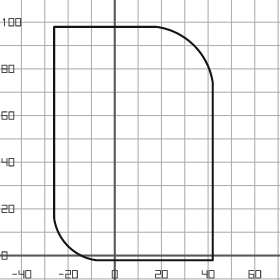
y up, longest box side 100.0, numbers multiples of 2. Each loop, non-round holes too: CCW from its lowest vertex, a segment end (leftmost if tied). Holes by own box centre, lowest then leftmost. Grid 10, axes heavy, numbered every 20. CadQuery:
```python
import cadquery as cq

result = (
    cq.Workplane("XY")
    .moveTo(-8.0, -2.0)
    .lineTo(42.0, -2.0)
    .lineTo(42.0, 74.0)
    .threePointArc((34.0, 90.0), (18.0, 98.0))
    .lineTo(-26.0, 98.0)
    .lineTo(-26.0, 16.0)
    .threePointArc((-20.0, 4.0), (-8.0, -2.0))
    .close()
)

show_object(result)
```